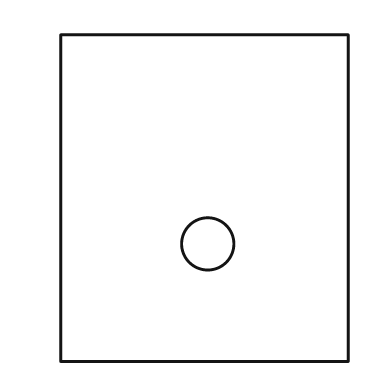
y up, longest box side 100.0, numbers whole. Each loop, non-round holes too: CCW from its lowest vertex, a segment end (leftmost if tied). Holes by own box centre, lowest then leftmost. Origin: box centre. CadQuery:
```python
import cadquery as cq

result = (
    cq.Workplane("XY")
    .moveTo(-44.0, -50.0)
    .lineTo(44.0, -50.0)
    .lineTo(44.0, 50.0)
    .lineTo(-44.0, 50.0)
    .close()
    .moveTo(1.0, -14.0)
    .circle(8.0)
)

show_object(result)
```